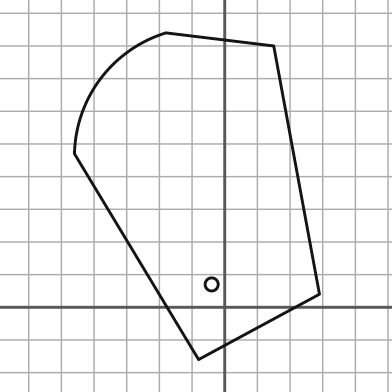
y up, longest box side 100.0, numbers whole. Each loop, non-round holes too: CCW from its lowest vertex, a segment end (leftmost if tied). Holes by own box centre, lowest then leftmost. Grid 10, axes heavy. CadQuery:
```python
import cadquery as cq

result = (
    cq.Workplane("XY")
    .moveTo(-8.0, -16.0)
    .lineTo(29.0, 4.0)
    .lineTo(15.0, 80.0)
    .lineTo(-18.0, 84.0)
    .threePointArc((-38.0, 70.0), (-46.0, 47.0))
    .close()
    .moveTo(-4.0, 7.0)
    .circle(2.0)
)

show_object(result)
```